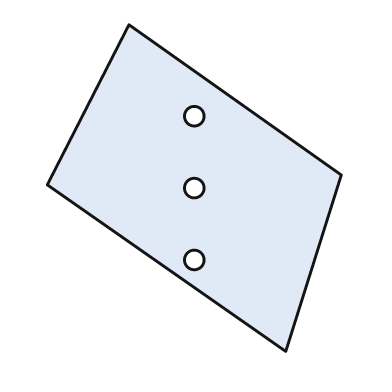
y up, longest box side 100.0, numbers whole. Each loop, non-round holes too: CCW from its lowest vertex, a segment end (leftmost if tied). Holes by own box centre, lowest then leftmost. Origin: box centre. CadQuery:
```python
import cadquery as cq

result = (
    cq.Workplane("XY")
    .moveTo(28.0, -50.0)
    .lineTo(45.0, 4.0)
    .lineTo(-20.0, 50.0)
    .lineTo(-45.0, 1.0)
    .close()
    .moveTo(0.0, -22.0)
    .circle(3.0)
    .moveTo(0.0, 0.0)
    .circle(3.0)
    .moveTo(0.0, 22.0)
    .circle(3.0)
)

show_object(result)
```